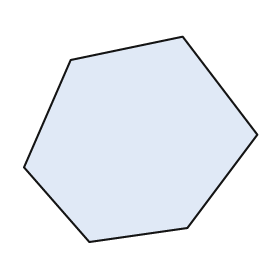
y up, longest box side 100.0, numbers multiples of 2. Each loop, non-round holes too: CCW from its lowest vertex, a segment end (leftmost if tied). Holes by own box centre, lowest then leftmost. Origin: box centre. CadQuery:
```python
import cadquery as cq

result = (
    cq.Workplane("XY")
    .moveTo(-22.0, -44.0)
    .lineTo(20.0, -38.0)
    .lineTo(50.0, 2.0)
    .lineTo(18.0, 44.0)
    .lineTo(-30.0, 34.0)
    .lineTo(-50.0, -12.0)
    .close()
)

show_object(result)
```